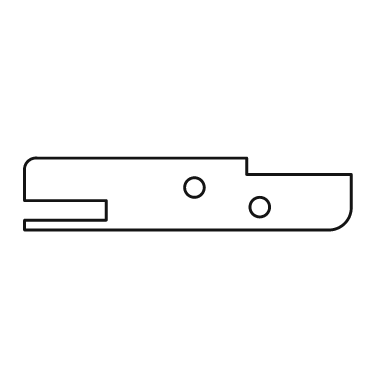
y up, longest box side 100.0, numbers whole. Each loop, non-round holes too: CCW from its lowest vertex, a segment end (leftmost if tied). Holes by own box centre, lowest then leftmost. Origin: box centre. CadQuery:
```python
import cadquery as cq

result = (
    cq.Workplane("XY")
    .moveTo(-50.0, -11.0)
    .lineTo(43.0, -11.0)
    .threePointArc((48.0, -9.0), (50.0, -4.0))
    .lineTo(50.0, 6.0)
    .lineTo(18.0, 6.0)
    .lineTo(18.0, 11.0)
    .lineTo(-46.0, 11.0)
    .threePointArc((-49.0, 10.0), (-50.0, 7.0))
    .lineTo(-50.0, -2.0)
    .lineTo(-25.0, -2.0)
    .lineTo(-25.0, -8.0)
    .lineTo(-50.0, -8.0)
    .close()
    .moveTo(22.0, -4.0)
    .circle(3.0)
    .moveTo(2.0, 2.0)
    .circle(3.0)
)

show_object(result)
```